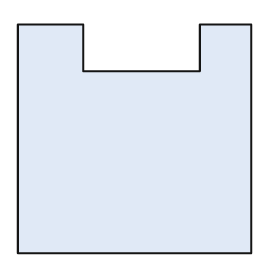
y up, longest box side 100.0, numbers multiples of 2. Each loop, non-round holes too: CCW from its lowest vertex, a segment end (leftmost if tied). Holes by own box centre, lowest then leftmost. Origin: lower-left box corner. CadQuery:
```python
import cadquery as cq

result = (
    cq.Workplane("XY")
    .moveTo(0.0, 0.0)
    .lineTo(100.0, 0.0)
    .lineTo(100.0, 98.0)
    .lineTo(78.0, 98.0)
    .lineTo(78.0, 78.0)
    .lineTo(28.0, 78.0)
    .lineTo(28.0, 98.0)
    .lineTo(0.0, 98.0)
    .close()
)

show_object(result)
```